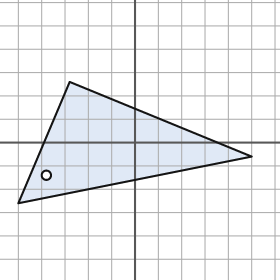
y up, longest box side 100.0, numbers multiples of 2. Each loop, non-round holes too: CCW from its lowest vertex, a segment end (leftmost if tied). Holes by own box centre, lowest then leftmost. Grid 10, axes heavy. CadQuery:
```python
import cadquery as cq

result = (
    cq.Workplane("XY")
    .moveTo(-50.0, -26.0)
    .lineTo(50.0, -6.0)
    .lineTo(-28.0, 26.0)
    .close()
    .moveTo(-38.0, -14.0)
    .circle(2.0)
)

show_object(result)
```